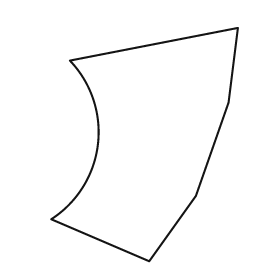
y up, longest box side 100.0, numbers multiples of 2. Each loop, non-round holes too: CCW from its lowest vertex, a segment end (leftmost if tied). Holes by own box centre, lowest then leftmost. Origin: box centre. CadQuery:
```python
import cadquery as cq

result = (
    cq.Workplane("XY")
    .moveTo(2.0, -50.0)
    .lineTo(22.0, -22.0)
    .lineTo(36.0, 18.0)
    .lineTo(40.0, 50.0)
    .lineTo(-32.0, 36.0)
    .threePointArc((-20.0, 0.0), (-40.0, -32.0))
    .close()
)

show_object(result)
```